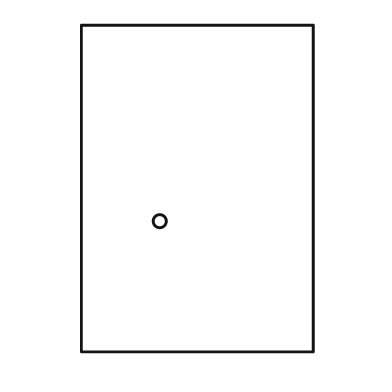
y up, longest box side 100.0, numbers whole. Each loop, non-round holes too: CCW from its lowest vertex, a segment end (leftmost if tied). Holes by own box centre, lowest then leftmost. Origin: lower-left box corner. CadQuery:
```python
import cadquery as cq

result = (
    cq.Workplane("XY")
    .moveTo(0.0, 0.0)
    .lineTo(71.0, 0.0)
    .lineTo(71.0, 100.0)
    .lineTo(0.0, 100.0)
    .close()
    .moveTo(24.0, 40.0)
    .circle(2.0)
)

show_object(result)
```